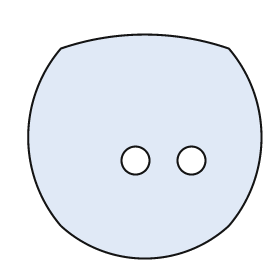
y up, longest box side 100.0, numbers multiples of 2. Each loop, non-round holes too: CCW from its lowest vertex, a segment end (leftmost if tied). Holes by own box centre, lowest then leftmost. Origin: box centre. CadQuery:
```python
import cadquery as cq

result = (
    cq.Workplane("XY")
    .moveTo(-36.0, -34.0)
    .threePointArc((0.0, -48.0), (36.0, -34.0))
    .threePointArc((50.0, 4.0), (36.0, 42.0))
    .threePointArc((0.0, 48.0), (-36.0, 42.0))
    .threePointArc((-50.0, 4.0), (-36.0, -34.0))
    .close()
    .moveTo(-4.0, -6.0)
    .circle(6.0)
    .moveTo(20.0, -6.0)
    .circle(6.0)
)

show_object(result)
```